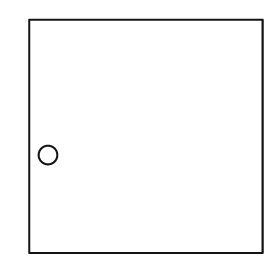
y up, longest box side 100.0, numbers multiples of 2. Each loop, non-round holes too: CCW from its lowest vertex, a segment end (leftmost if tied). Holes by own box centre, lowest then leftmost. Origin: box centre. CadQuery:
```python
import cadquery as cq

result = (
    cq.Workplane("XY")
    .moveTo(-50.0, -50.0)
    .lineTo(50.0, -50.0)
    .lineTo(50.0, 50.0)
    .lineTo(-50.0, 50.0)
    .close()
    .moveTo(-42.0, -8.0)
    .circle(4.0)
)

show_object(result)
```